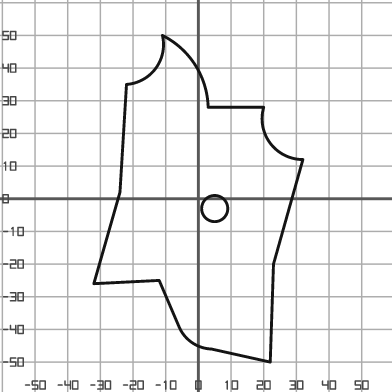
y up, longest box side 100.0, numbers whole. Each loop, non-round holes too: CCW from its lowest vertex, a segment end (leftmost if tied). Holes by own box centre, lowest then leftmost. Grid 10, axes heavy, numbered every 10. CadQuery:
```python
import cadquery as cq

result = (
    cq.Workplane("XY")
    .moveTo(22.0, -50.0)
    .lineTo(23.0, -20.0)
    .lineTo(32.0, 12.0)
    .threePointArc((22.0, 17.0), (20.0, 28.0))
    .lineTo(3.0, 28.0)
    .threePointArc((-1.0, 41.0), (-11.0, 50.0))
    .threePointArc((-13.0, 40.0), (-22.0, 35.0))
    .lineTo(-24.0, 2.0)
    .lineTo(-32.0, -26.0)
    .lineTo(-12.0, -25.0)
    .lineTo(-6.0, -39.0)
    .threePointArc((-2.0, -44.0), (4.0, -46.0))
    .close()
    .moveTo(5.0, -3.0)
    .circle(4.0)
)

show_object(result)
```